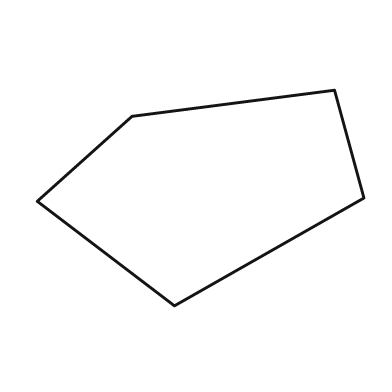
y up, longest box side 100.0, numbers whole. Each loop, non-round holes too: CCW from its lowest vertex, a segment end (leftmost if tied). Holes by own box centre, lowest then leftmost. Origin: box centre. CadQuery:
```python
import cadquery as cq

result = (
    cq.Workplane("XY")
    .moveTo(-8.0, -33.0)
    .lineTo(50.0, 0.0)
    .lineTo(41.0, 33.0)
    .lineTo(-21.0, 25.0)
    .lineTo(-50.0, -1.0)
    .close()
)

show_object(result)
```